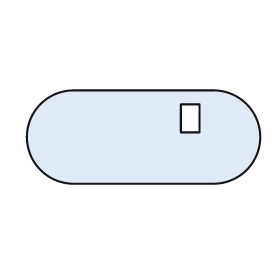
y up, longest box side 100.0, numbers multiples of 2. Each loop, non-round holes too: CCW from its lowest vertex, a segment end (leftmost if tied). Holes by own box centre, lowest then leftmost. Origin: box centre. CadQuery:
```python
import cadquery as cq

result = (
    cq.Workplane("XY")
    .moveTo(-30.0, -20.0)
    .lineTo(30.0, -20.0)
    .threePointArc((50.0, 0.0), (30.0, 20.0))
    .lineTo(-30.0, 20.0)
    .threePointArc((-50.0, 0.0), (-30.0, -20.0))
    .close()
    .moveTo(16.0, 2.0)
    .lineTo(24.0, 2.0)
    .lineTo(24.0, 14.0)
    .lineTo(16.0, 14.0)
    .close()
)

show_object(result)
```